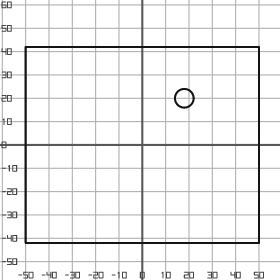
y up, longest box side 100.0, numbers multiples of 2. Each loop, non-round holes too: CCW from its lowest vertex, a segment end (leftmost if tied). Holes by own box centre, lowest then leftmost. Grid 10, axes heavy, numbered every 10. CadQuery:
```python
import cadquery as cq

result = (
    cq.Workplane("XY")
    .moveTo(-50.0, -42.0)
    .lineTo(50.0, -42.0)
    .lineTo(50.0, 42.0)
    .lineTo(-50.0, 42.0)
    .close()
    .moveTo(18.0, 20.0)
    .circle(4.0)
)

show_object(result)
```